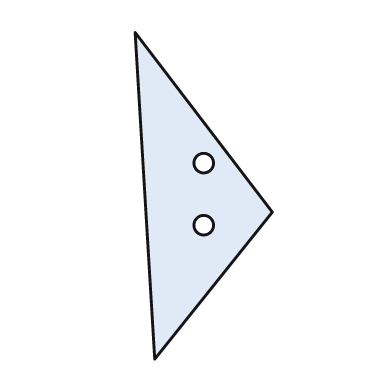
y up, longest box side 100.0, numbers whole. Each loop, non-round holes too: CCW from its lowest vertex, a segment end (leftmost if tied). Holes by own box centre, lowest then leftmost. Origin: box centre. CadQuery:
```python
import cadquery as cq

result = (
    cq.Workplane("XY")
    .moveTo(-15.0, -50.0)
    .lineTo(21.0, -5.0)
    .lineTo(-21.0, 50.0)
    .close()
    .moveTo(0.0, -9.0)
    .circle(3.0)
    .moveTo(0.0, 10.0)
    .circle(3.0)
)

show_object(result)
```